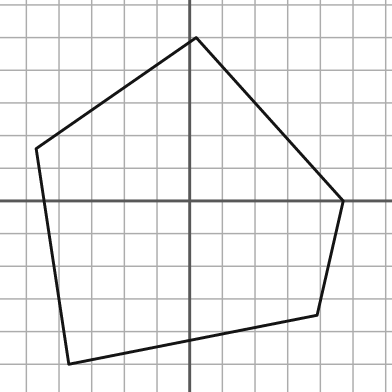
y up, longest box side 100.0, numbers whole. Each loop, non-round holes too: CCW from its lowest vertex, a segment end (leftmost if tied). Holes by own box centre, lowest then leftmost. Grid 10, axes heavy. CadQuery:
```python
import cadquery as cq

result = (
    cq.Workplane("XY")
    .moveTo(-37.0, -50.0)
    .lineTo(39.0, -35.0)
    .lineTo(47.0, 0.0)
    .lineTo(2.0, 50.0)
    .lineTo(-47.0, 16.0)
    .close()
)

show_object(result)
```